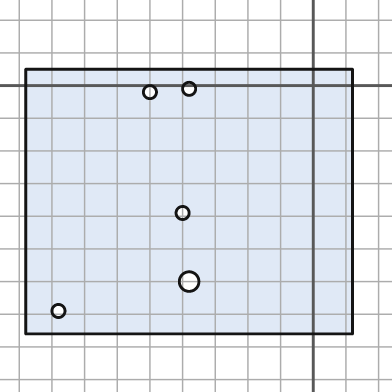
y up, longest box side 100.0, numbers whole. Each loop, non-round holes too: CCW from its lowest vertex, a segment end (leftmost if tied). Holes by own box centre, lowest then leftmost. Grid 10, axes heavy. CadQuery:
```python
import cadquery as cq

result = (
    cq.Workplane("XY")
    .moveTo(-88.0, -76.0)
    .lineTo(12.0, -76.0)
    .lineTo(12.0, 5.0)
    .lineTo(-88.0, 5.0)
    .close()
    .moveTo(-78.0, -69.0)
    .circle(2.0)
    .moveTo(-38.0, -60.0)
    .circle(3.0)
    .moveTo(-40.0, -39.0)
    .circle(2.0)
    .moveTo(-50.0, -2.0)
    .circle(2.0)
    .moveTo(-38.0, -1.0)
    .circle(2.0)
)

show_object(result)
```